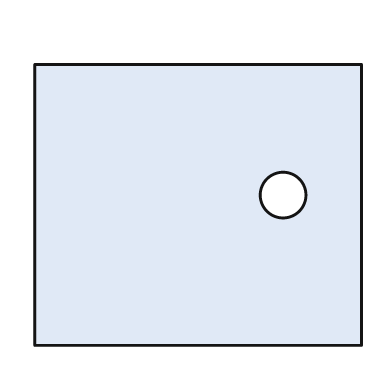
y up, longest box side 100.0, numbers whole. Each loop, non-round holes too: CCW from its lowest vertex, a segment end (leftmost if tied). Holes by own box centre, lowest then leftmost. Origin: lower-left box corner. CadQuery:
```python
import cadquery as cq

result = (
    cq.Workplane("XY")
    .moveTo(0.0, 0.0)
    .lineTo(100.0, 0.0)
    .lineTo(100.0, 86.0)
    .lineTo(0.0, 86.0)
    .close()
    .moveTo(76.0, 46.0)
    .circle(7.0)
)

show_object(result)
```